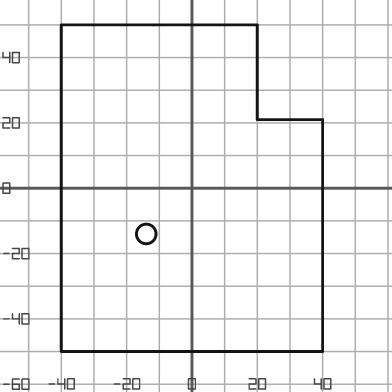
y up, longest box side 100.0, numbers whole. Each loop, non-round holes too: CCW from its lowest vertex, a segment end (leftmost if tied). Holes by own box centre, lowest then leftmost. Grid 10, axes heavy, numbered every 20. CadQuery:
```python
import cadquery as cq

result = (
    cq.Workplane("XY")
    .moveTo(-40.0, -50.0)
    .lineTo(40.0, -50.0)
    .lineTo(40.0, 21.0)
    .lineTo(20.0, 21.0)
    .lineTo(20.0, 50.0)
    .lineTo(-40.0, 50.0)
    .close()
    .moveTo(-14.0, -14.0)
    .circle(3.0)
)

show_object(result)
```